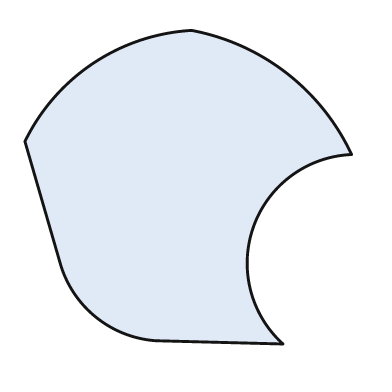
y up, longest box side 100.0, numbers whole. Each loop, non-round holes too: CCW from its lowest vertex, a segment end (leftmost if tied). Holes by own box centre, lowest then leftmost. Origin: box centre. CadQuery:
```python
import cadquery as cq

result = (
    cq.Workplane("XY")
    .moveTo(29.0, -48.0)
    .threePointArc((20.0, -12.0), (50.0, 10.0))
    .threePointArc((30.0, 35.0), (1.0, 48.0))
    .threePointArc((-29.0, 38.0), (-50.0, 14.0))
    .lineTo(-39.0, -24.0)
    .threePointArc((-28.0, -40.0), (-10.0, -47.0))
    .close()
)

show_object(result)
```